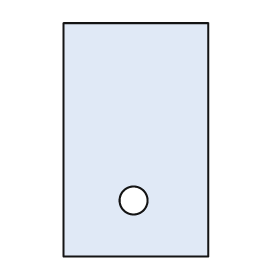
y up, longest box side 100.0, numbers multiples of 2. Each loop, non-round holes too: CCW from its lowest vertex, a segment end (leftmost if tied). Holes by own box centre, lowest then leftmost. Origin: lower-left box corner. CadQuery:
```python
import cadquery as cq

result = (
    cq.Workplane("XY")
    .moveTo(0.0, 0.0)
    .lineTo(62.0, 0.0)
    .lineTo(62.0, 100.0)
    .lineTo(0.0, 100.0)
    .close()
    .moveTo(30.0, 24.0)
    .circle(6.0)
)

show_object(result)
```